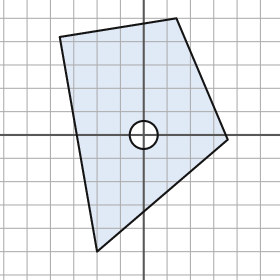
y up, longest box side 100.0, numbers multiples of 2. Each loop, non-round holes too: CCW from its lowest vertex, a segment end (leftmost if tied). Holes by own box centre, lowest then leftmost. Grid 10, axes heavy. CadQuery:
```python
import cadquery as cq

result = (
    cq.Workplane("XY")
    .moveTo(-20.0, -50.0)
    .lineTo(36.0, -2.0)
    .lineTo(14.0, 50.0)
    .lineTo(-36.0, 42.0)
    .close()
    .moveTo(0.0, 0.0)
    .circle(6.0)
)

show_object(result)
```